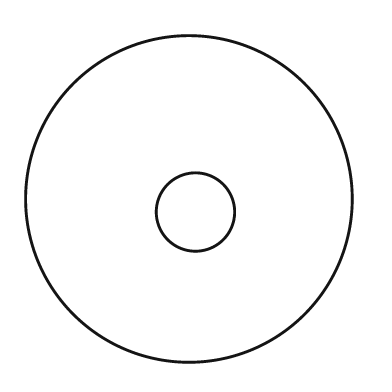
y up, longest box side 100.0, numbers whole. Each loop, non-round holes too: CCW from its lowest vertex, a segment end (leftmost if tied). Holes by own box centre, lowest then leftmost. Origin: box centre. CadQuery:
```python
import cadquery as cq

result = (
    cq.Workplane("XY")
    .moveTo(0.0, 0.0)
    .circle(50.0)
    .moveTo(2.0, -4.0)
    .circle(12.0)
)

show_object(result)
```